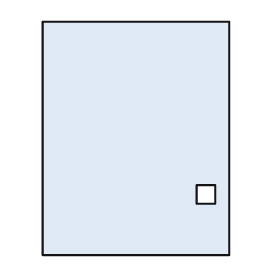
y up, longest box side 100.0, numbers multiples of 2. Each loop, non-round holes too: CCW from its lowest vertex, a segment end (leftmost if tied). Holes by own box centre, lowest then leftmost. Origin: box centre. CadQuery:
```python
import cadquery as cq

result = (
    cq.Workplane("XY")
    .moveTo(-40.0, -50.0)
    .lineTo(40.0, -50.0)
    .lineTo(40.0, 50.0)
    .lineTo(-40.0, 50.0)
    .close()
    .moveTo(26.0, -28.0)
    .lineTo(34.0, -28.0)
    .lineTo(34.0, -20.0)
    .lineTo(26.0, -20.0)
    .close()
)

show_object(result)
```